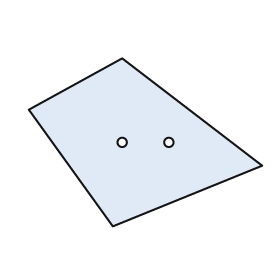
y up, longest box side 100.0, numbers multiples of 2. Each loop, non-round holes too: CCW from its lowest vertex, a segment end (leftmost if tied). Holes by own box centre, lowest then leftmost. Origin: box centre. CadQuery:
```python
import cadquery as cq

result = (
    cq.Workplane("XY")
    .moveTo(-14.0, -36.0)
    .lineTo(50.0, -10.0)
    .lineTo(-10.0, 36.0)
    .lineTo(-50.0, 14.0)
    .close()
    .moveTo(-10.0, 0.0)
    .circle(2.0)
    .moveTo(10.0, 0.0)
    .circle(2.0)
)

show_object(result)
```